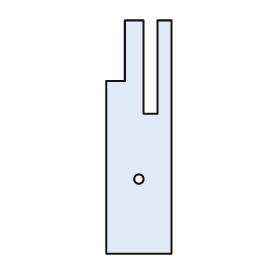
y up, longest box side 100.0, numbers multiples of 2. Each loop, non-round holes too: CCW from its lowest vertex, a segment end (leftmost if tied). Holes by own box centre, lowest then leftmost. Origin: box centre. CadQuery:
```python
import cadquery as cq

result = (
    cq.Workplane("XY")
    .moveTo(-14.0, -50.0)
    .lineTo(14.0, -50.0)
    .lineTo(14.0, 50.0)
    .lineTo(8.0, 50.0)
    .lineTo(8.0, 10.0)
    .lineTo(2.0, 10.0)
    .lineTo(2.0, 50.0)
    .lineTo(-6.0, 50.0)
    .lineTo(-6.0, 24.0)
    .lineTo(-14.0, 24.0)
    .close()
    .moveTo(0.0, -18.0)
    .circle(2.0)
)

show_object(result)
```